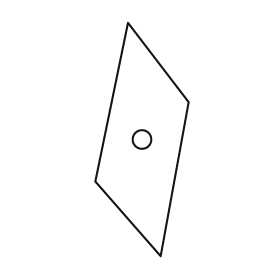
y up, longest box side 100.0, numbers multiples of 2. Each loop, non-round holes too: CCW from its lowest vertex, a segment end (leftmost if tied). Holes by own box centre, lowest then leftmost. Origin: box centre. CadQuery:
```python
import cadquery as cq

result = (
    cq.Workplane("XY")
    .moveTo(8.0, -50.0)
    .lineTo(20.0, 16.0)
    .lineTo(-6.0, 50.0)
    .lineTo(-20.0, -18.0)
    .close()
    .moveTo(0.0, 0.0)
    .circle(4.0)
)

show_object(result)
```